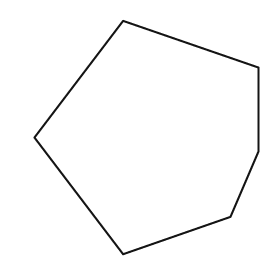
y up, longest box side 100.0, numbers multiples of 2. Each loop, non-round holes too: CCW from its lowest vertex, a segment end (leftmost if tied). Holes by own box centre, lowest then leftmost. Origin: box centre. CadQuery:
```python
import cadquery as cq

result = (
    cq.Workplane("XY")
    .moveTo(-10.0, -50.0)
    .lineTo(36.0, -34.0)
    .lineTo(48.0, -6.0)
    .lineTo(48.0, 30.0)
    .lineTo(-10.0, 50.0)
    .lineTo(-48.0, 0.0)
    .close()
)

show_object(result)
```